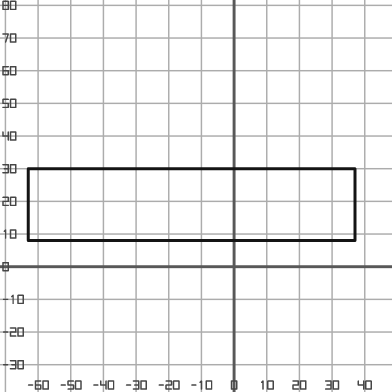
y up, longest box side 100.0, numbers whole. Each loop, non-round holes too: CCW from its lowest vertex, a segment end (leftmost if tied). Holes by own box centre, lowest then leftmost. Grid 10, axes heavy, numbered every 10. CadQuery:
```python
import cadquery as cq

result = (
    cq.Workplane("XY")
    .moveTo(-63.0, 8.0)
    .lineTo(37.0, 8.0)
    .lineTo(37.0, 30.0)
    .lineTo(-63.0, 30.0)
    .close()
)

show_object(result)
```